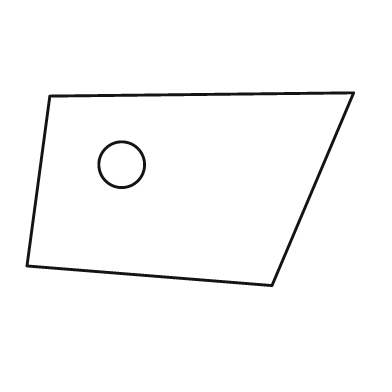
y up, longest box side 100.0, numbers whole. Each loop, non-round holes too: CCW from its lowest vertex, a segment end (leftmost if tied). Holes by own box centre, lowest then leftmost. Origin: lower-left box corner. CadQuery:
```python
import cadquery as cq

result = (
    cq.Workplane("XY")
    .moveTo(75.0, 0.0)
    .lineTo(100.0, 59.0)
    .lineTo(7.0, 58.0)
    .lineTo(0.0, 6.0)
    .close()
    .moveTo(29.0, 37.0)
    .circle(7.0)
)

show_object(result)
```